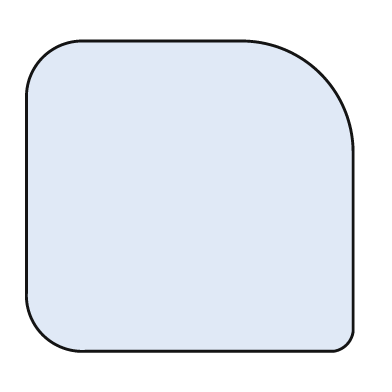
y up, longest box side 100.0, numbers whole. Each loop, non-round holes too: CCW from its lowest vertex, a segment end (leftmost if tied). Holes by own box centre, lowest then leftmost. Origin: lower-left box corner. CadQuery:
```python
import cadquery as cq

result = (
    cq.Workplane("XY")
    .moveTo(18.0, 0.0)
    .lineTo(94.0, 0.0)
    .threePointArc((98.0, 2.0), (100.0, 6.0))
    .lineTo(100.0, 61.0)
    .threePointArc((90.0, 85.0), (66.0, 95.0))
    .lineTo(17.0, 95.0)
    .threePointArc((5.0, 90.0), (0.0, 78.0))
    .lineTo(0.0, 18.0)
    .threePointArc((5.0, 5.0), (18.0, 0.0))
    .close()
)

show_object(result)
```